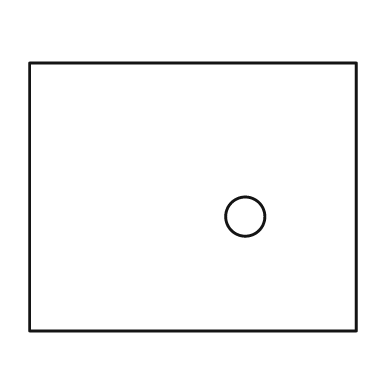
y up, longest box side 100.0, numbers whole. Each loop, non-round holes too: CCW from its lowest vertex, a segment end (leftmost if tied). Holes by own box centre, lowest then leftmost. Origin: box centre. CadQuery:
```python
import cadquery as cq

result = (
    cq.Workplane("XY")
    .moveTo(-50.0, -41.0)
    .lineTo(50.0, -41.0)
    .lineTo(50.0, 41.0)
    .lineTo(-50.0, 41.0)
    .close()
    .moveTo(16.0, -6.0)
    .circle(6.0)
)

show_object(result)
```